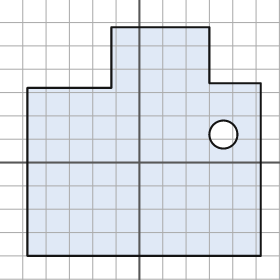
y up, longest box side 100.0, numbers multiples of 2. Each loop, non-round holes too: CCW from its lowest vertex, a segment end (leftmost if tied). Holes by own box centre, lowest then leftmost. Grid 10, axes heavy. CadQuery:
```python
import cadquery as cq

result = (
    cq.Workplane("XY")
    .moveTo(-48.0, -40.0)
    .lineTo(52.0, -40.0)
    .lineTo(52.0, 34.0)
    .lineTo(30.0, 34.0)
    .lineTo(30.0, 58.0)
    .lineTo(-12.0, 58.0)
    .lineTo(-12.0, 32.0)
    .lineTo(-48.0, 32.0)
    .close()
    .moveTo(36.0, 12.0)
    .circle(6.0)
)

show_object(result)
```